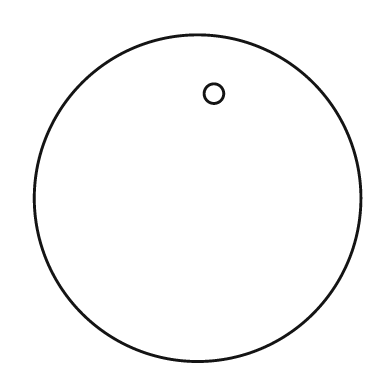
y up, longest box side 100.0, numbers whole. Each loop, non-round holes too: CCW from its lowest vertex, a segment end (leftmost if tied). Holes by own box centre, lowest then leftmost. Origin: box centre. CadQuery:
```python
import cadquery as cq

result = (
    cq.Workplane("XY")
    .moveTo(0.0, 0.0)
    .circle(50.0)
    .moveTo(5.0, 32.0)
    .circle(3.0)
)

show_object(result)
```